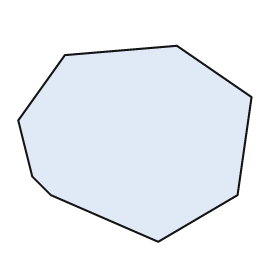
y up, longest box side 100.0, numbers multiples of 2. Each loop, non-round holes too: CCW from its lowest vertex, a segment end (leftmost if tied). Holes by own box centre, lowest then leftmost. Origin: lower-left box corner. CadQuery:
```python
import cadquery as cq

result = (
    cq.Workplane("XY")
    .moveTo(60.0, 0.0)
    .lineTo(94.0, 20.0)
    .lineTo(100.0, 62.0)
    .lineTo(68.0, 84.0)
    .lineTo(20.0, 80.0)
    .lineTo(0.0, 52.0)
    .lineTo(6.0, 28.0)
    .lineTo(14.0, 20.0)
    .close()
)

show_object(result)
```